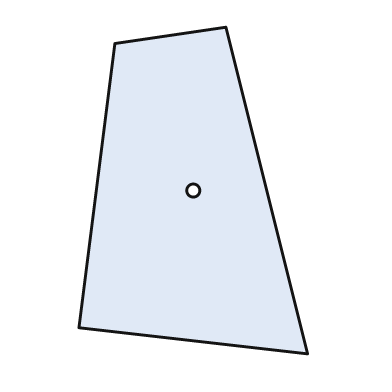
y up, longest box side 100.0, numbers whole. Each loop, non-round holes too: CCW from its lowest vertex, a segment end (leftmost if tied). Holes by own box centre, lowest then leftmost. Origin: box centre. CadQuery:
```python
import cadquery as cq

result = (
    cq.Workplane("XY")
    .moveTo(35.0, -50.0)
    .lineTo(10.0, 50.0)
    .lineTo(-24.0, 45.0)
    .lineTo(-35.0, -42.0)
    .close()
    .moveTo(0.0, 0.0)
    .circle(2.0)
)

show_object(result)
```